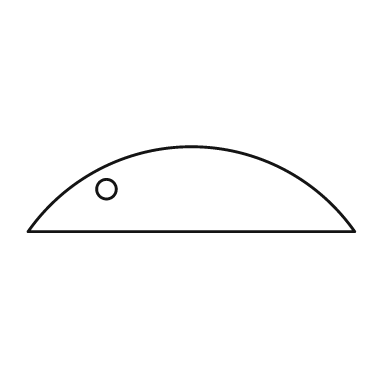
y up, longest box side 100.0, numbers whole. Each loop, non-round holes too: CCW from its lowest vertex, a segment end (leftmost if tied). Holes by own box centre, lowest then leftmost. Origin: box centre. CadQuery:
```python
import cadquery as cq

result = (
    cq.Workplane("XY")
    .moveTo(-50.0, -13.0)
    .lineTo(50.0, -13.0)
    .threePointArc((0.0, 13.0), (-50.0, -13.0))
    .close()
    .moveTo(-26.0, 0.0)
    .circle(3.0)
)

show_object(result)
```